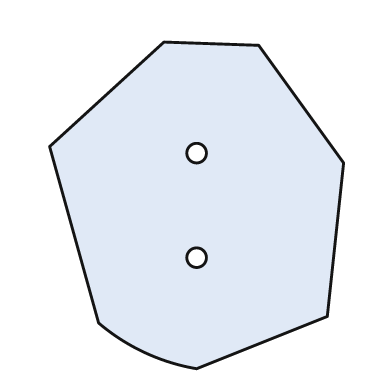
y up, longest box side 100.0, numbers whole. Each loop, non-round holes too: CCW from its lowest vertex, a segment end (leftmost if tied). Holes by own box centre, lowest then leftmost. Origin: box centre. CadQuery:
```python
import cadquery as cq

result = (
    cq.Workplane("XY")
    .moveTo(0.0, -50.0)
    .lineTo(40.0, -34.0)
    .lineTo(45.0, 13.0)
    .lineTo(19.0, 49.0)
    .lineTo(-10.0, 50.0)
    .lineTo(-45.0, 18.0)
    .lineTo(-30.0, -36.0)
    .threePointArc((-16.0, -45.0), (0.0, -50.0))
    .close()
    .moveTo(0.0, -16.0)
    .circle(3.0)
    .moveTo(0.0, 16.0)
    .circle(3.0)
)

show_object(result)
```